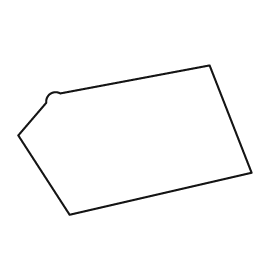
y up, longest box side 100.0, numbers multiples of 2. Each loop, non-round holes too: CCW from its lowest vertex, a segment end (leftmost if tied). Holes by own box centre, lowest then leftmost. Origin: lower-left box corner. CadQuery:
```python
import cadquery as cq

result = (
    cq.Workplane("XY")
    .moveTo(22.0, 0.0)
    .lineTo(100.0, 18.0)
    .lineTo(82.0, 64.0)
    .lineTo(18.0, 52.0)
    .threePointArc((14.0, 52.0), (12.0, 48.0))
    .lineTo(0.0, 34.0)
    .close()
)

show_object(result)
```